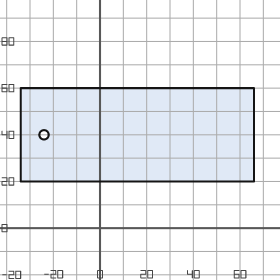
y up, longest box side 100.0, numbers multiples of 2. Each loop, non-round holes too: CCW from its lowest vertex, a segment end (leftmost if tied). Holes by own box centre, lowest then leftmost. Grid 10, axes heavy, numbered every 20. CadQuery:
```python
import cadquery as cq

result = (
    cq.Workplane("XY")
    .moveTo(-34.0, 20.0)
    .lineTo(66.0, 20.0)
    .lineTo(66.0, 60.0)
    .lineTo(-34.0, 60.0)
    .close()
    .moveTo(-24.0, 40.0)
    .circle(2.0)
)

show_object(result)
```